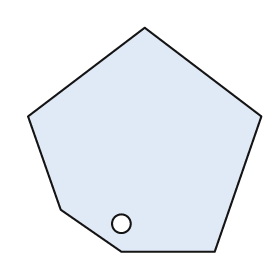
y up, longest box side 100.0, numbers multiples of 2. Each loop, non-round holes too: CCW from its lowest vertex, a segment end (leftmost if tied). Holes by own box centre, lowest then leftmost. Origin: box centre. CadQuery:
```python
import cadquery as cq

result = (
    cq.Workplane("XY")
    .moveTo(-10.0, -48.0)
    .lineTo(30.0, -48.0)
    .lineTo(50.0, 10.0)
    .lineTo(0.0, 48.0)
    .lineTo(-50.0, 10.0)
    .lineTo(-36.0, -30.0)
    .close()
    .moveTo(-10.0, -36.0)
    .circle(4.0)
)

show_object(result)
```